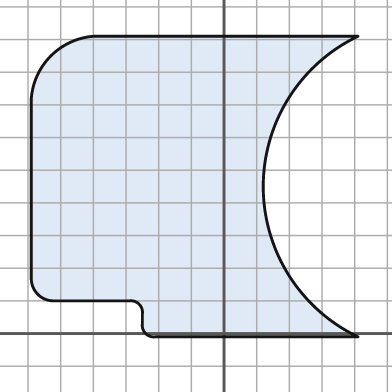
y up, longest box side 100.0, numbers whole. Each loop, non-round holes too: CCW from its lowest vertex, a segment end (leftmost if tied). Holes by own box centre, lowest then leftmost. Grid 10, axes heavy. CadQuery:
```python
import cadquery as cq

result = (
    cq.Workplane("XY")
    .moveTo(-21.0, -1.0)
    .lineTo(41.0, -1.0)
    .threePointArc((12.0, 45.0), (41.0, 91.0))
    .lineTo(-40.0, 91.0)
    .threePointArc((-53.0, 85.0), (-59.0, 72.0))
    .lineTo(-59.0, 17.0)
    .threePointArc((-57.0, 12.0), (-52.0, 10.0))
    .lineTo(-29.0, 10.0)
    .threePointArc((-26.0, 9.0), (-25.0, 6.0))
    .lineTo(-25.0, 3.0)
    .threePointArc((-24.0, 0.0), (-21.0, -1.0))
    .close()
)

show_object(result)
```